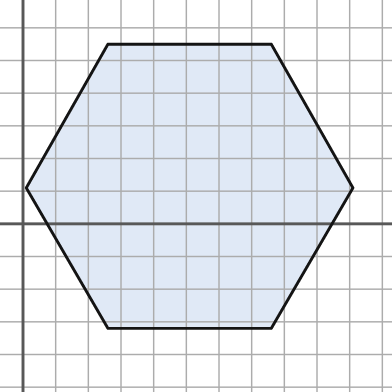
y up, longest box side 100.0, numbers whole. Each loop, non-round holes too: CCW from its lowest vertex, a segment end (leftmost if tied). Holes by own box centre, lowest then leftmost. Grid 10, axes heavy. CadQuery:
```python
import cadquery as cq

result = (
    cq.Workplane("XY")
    .moveTo(26.0, -32.0)
    .lineTo(76.0, -32.0)
    .lineTo(101.0, 11.0)
    .lineTo(76.0, 55.0)
    .lineTo(26.0, 55.0)
    .lineTo(1.0, 11.0)
    .close()
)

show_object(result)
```